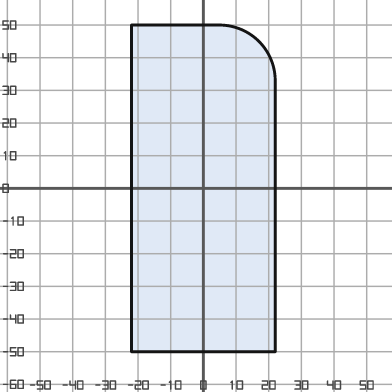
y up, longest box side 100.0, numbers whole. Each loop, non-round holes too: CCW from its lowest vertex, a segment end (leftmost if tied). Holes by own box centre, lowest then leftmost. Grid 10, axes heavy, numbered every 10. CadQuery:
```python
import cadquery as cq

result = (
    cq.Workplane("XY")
    .moveTo(-22.0, -50.0)
    .lineTo(22.0, -50.0)
    .lineTo(22.0, 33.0)
    .threePointArc((17.0, 45.0), (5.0, 50.0))
    .lineTo(-22.0, 50.0)
    .close()
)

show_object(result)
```